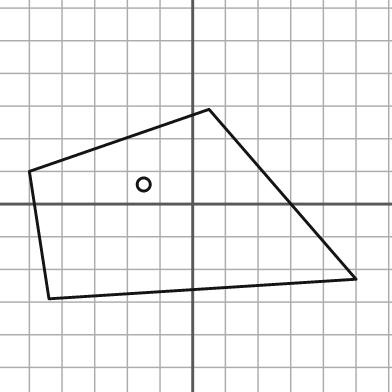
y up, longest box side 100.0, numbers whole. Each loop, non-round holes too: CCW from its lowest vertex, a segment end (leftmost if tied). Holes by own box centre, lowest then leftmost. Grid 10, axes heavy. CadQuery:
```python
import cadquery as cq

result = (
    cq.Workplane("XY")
    .moveTo(-44.0, -29.0)
    .lineTo(50.0, -23.0)
    .lineTo(5.0, 29.0)
    .lineTo(-50.0, 10.0)
    .close()
    .moveTo(-15.0, 6.0)
    .circle(2.0)
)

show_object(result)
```